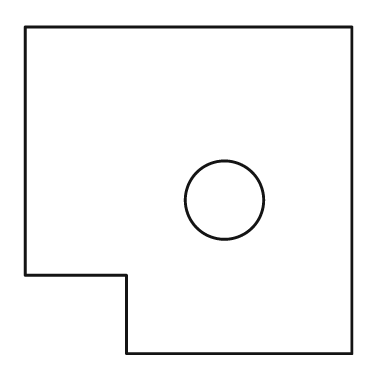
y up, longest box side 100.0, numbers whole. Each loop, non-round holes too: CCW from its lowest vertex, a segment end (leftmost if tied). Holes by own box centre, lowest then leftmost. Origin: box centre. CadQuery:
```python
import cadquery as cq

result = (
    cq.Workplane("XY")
    .moveTo(-19.0, -50.0)
    .lineTo(50.0, -50.0)
    .lineTo(50.0, 50.0)
    .lineTo(-50.0, 50.0)
    .lineTo(-50.0, -26.0)
    .lineTo(-19.0, -26.0)
    .close()
    .moveTo(11.0, -3.0)
    .circle(12.0)
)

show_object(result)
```